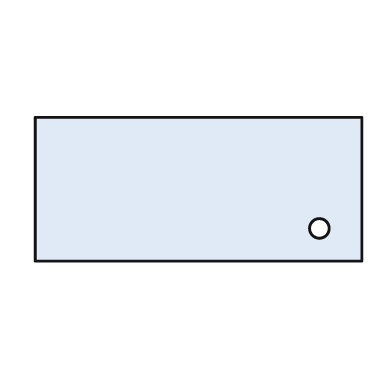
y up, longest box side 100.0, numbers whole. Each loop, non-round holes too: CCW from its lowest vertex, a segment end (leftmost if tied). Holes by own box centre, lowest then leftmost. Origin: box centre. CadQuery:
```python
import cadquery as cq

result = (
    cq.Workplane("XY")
    .moveTo(-50.0, -22.0)
    .lineTo(50.0, -22.0)
    .lineTo(50.0, 22.0)
    .lineTo(-50.0, 22.0)
    .close()
    .moveTo(37.0, -12.0)
    .circle(3.0)
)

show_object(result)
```